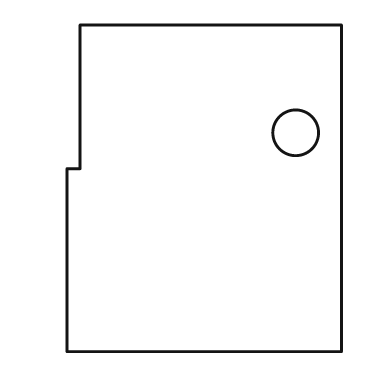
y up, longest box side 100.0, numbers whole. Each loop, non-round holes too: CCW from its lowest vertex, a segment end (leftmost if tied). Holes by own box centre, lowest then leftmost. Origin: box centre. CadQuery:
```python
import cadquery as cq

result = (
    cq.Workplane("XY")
    .moveTo(-42.0, -50.0)
    .lineTo(42.0, -50.0)
    .lineTo(42.0, 50.0)
    .lineTo(-38.0, 50.0)
    .lineTo(-38.0, 6.0)
    .lineTo(-42.0, 6.0)
    .close()
    .moveTo(28.0, 17.0)
    .circle(7.0)
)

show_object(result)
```